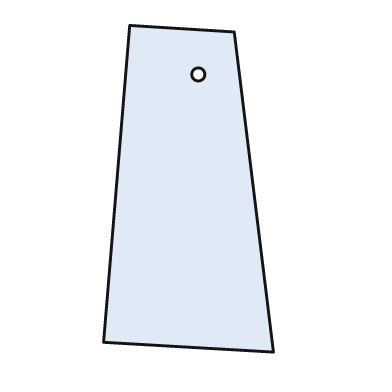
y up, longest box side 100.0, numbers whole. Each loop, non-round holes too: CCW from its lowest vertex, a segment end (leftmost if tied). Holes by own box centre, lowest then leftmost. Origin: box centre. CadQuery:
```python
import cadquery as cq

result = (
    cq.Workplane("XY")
    .moveTo(26.0, -50.0)
    .lineTo(14.0, 48.0)
    .lineTo(-18.0, 50.0)
    .lineTo(-26.0, -47.0)
    .close()
    .moveTo(3.0, 35.0)
    .circle(2.0)
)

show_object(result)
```